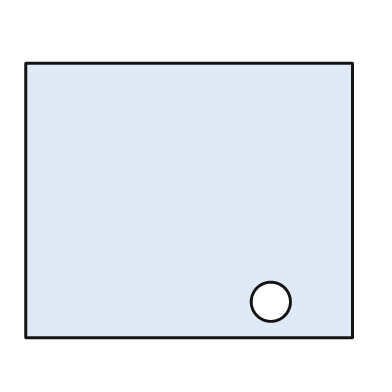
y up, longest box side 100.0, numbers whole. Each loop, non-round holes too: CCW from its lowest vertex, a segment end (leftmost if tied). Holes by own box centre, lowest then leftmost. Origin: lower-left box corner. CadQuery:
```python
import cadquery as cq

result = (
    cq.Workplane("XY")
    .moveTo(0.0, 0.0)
    .lineTo(100.0, 0.0)
    .lineTo(100.0, 84.0)
    .lineTo(0.0, 84.0)
    .close()
    .moveTo(75.0, 11.0)
    .circle(6.0)
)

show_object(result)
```